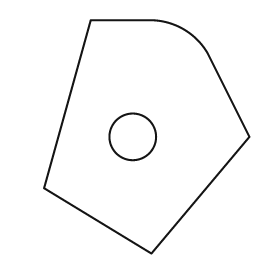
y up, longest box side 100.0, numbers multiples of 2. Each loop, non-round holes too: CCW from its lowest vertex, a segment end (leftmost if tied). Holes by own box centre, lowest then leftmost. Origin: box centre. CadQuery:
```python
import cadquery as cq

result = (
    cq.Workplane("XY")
    .moveTo(2.0, -50.0)
    .lineTo(44.0, 0.0)
    .lineTo(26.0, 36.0)
    .threePointArc((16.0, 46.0), (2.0, 50.0))
    .lineTo(-24.0, 50.0)
    .lineTo(-44.0, -22.0)
    .close()
    .moveTo(-6.0, 0.0)
    .circle(10.0)
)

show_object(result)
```